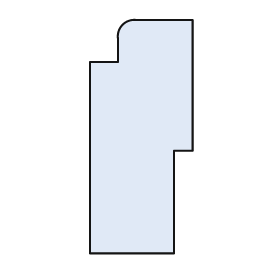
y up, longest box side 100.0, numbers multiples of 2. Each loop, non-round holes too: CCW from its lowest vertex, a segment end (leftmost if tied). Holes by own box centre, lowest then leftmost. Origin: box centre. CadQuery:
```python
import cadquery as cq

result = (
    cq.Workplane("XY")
    .moveTo(-22.0, -50.0)
    .lineTo(14.0, -50.0)
    .lineTo(14.0, -6.0)
    .lineTo(22.0, -6.0)
    .lineTo(22.0, 50.0)
    .lineTo(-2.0, 50.0)
    .threePointArc((-8.0, 48.0), (-10.0, 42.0))
    .lineTo(-10.0, 32.0)
    .lineTo(-22.0, 32.0)
    .close()
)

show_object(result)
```